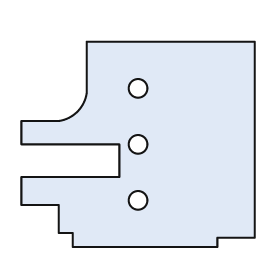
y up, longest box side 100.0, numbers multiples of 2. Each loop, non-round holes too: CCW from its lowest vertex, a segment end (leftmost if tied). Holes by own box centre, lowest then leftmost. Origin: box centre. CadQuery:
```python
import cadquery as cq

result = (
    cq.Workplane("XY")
    .moveTo(-28.0, -44.0)
    .lineTo(34.0, -44.0)
    .lineTo(34.0, -40.0)
    .lineTo(50.0, -40.0)
    .lineTo(50.0, 44.0)
    .lineTo(-22.0, 44.0)
    .lineTo(-22.0, 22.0)
    .threePointArc((-26.0, 14.0), (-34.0, 10.0))
    .lineTo(-50.0, 10.0)
    .lineTo(-50.0, 0.0)
    .lineTo(-8.0, 0.0)
    .lineTo(-8.0, -14.0)
    .lineTo(-50.0, -14.0)
    .lineTo(-50.0, -26.0)
    .lineTo(-34.0, -26.0)
    .lineTo(-34.0, -38.0)
    .lineTo(-28.0, -38.0)
    .close()
    .moveTo(0.0, -24.0)
    .circle(4.0)
    .moveTo(0.0, 0.0)
    .circle(4.0)
    .moveTo(0.0, 24.0)
    .circle(4.0)
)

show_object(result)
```